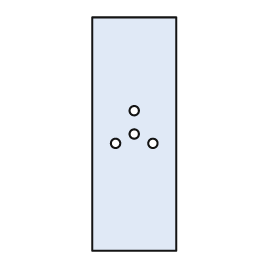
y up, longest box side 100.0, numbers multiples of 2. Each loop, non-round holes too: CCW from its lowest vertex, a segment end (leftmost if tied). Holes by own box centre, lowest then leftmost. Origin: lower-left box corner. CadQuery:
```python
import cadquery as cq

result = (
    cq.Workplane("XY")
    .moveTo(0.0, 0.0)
    .lineTo(36.0, 0.0)
    .lineTo(36.0, 100.0)
    .lineTo(0.0, 100.0)
    .close()
    .moveTo(10.0, 46.0)
    .circle(2.0)
    .moveTo(26.0, 46.0)
    .circle(2.0)
    .moveTo(18.0, 50.0)
    .circle(2.0)
    .moveTo(18.0, 60.0)
    .circle(2.0)
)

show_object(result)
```